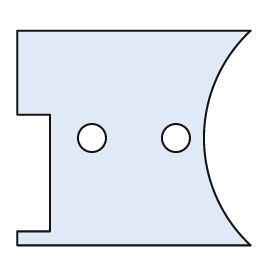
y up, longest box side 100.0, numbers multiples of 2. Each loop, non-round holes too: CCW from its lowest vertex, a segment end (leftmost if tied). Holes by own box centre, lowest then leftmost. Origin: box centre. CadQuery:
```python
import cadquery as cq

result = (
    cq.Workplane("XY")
    .moveTo(-50.0, -46.0)
    .lineTo(50.0, -46.0)
    .threePointArc((30.0, 0.0), (50.0, 46.0))
    .lineTo(-50.0, 46.0)
    .lineTo(-50.0, 10.0)
    .lineTo(-36.0, 10.0)
    .lineTo(-36.0, -40.0)
    .lineTo(-50.0, -40.0)
    .close()
    .moveTo(-18.0, 0.0)
    .circle(6.0)
    .moveTo(18.0, 0.0)
    .circle(6.0)
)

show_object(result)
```